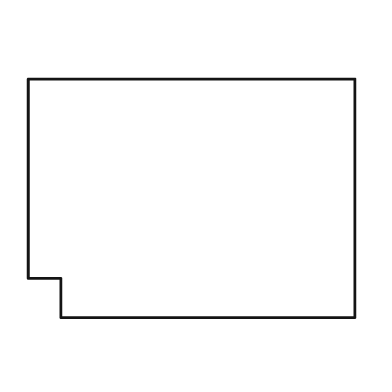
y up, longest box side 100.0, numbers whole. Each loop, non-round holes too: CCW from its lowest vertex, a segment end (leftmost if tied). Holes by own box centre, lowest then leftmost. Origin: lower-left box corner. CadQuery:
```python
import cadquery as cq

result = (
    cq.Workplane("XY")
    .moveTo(10.0, 0.0)
    .lineTo(100.0, 0.0)
    .lineTo(100.0, 73.0)
    .lineTo(0.0, 73.0)
    .lineTo(0.0, 12.0)
    .lineTo(10.0, 12.0)
    .close()
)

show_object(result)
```